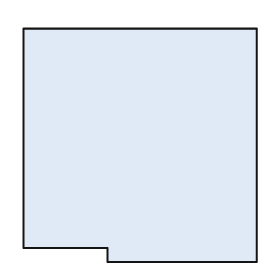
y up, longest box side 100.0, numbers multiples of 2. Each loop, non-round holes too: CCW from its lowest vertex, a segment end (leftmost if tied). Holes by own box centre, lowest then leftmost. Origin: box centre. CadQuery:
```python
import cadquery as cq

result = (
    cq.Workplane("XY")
    .moveTo(-14.0, -50.0)
    .lineTo(50.0, -50.0)
    .lineTo(50.0, 50.0)
    .lineTo(-50.0, 50.0)
    .lineTo(-50.0, -44.0)
    .lineTo(-14.0, -44.0)
    .close()
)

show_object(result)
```